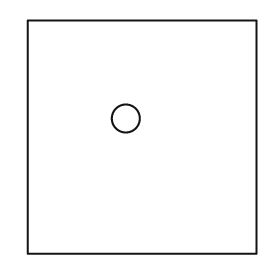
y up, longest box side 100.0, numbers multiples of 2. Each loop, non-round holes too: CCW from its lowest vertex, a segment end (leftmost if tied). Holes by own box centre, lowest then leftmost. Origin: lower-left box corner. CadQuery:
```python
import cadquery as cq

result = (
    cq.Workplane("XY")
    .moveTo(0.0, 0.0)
    .lineTo(98.0, 0.0)
    .lineTo(98.0, 100.0)
    .lineTo(0.0, 100.0)
    .close()
    .moveTo(42.0, 58.0)
    .circle(6.0)
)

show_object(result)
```